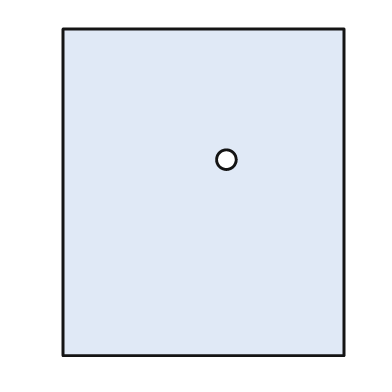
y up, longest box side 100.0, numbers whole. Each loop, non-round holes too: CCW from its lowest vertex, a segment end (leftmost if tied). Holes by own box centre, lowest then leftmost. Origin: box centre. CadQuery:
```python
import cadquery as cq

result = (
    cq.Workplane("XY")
    .moveTo(-43.0, -50.0)
    .lineTo(43.0, -50.0)
    .lineTo(43.0, 50.0)
    .lineTo(-43.0, 50.0)
    .close()
    .moveTo(7.0, 10.0)
    .circle(3.0)
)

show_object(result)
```